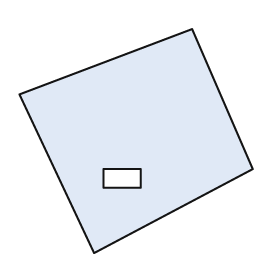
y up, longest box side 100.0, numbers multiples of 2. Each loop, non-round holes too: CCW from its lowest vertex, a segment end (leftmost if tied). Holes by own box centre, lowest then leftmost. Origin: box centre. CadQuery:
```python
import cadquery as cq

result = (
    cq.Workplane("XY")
    .moveTo(-18.0, -48.0)
    .lineTo(50.0, -12.0)
    .lineTo(24.0, 48.0)
    .lineTo(-50.0, 20.0)
    .close()
    .moveTo(-14.0, -20.0)
    .lineTo(2.0, -20.0)
    .lineTo(2.0, -12.0)
    .lineTo(-14.0, -12.0)
    .close()
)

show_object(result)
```